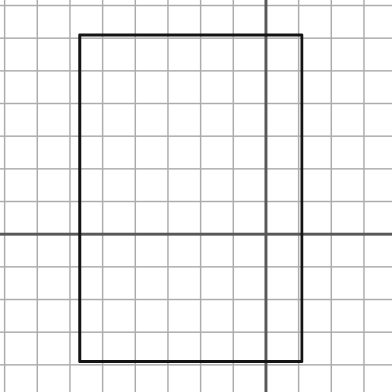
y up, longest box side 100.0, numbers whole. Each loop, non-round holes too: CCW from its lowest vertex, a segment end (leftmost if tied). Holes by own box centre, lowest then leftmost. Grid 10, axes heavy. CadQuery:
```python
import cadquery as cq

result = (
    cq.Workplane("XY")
    .moveTo(-57.0, -39.0)
    .lineTo(11.0, -39.0)
    .lineTo(11.0, 61.0)
    .lineTo(-57.0, 61.0)
    .close()
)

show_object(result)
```